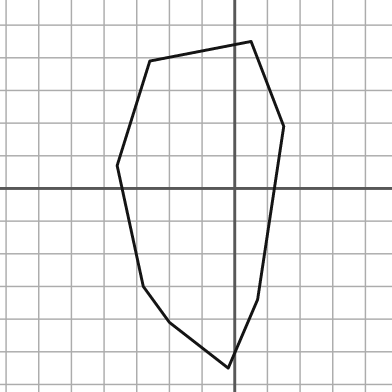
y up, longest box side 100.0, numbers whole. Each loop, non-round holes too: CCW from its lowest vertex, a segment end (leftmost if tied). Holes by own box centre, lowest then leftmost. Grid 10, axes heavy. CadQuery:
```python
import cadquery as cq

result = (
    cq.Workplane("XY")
    .moveTo(-2.0, -55.0)
    .lineTo(7.0, -34.0)
    .lineTo(15.0, 19.0)
    .lineTo(5.0, 45.0)
    .lineTo(-26.0, 39.0)
    .lineTo(-36.0, 7.0)
    .lineTo(-28.0, -30.0)
    .lineTo(-20.0, -41.0)
    .close()
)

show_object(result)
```